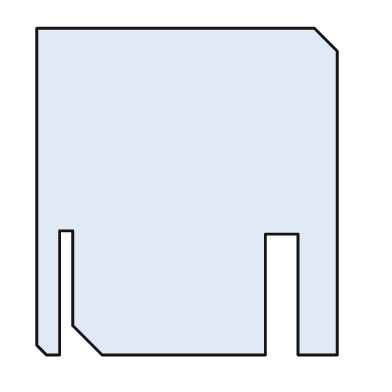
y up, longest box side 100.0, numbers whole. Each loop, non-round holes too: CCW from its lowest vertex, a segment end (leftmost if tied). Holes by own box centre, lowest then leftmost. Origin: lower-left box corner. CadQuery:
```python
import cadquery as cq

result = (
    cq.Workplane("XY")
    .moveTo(3.0, 0.0)
    .lineTo(7.0, 0.0)
    .lineTo(7.0, 38.0)
    .lineTo(11.0, 38.0)
    .lineTo(11.0, 9.0)
    .lineTo(20.0, 0.0)
    .lineTo(70.0, 0.0)
    .lineTo(70.0, 37.0)
    .lineTo(80.0, 37.0)
    .lineTo(80.0, 0.0)
    .lineTo(92.0, 0.0)
    .lineTo(92.0, 93.0)
    .lineTo(85.0, 100.0)
    .lineTo(0.0, 100.0)
    .lineTo(0.0, 3.0)
    .close()
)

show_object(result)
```